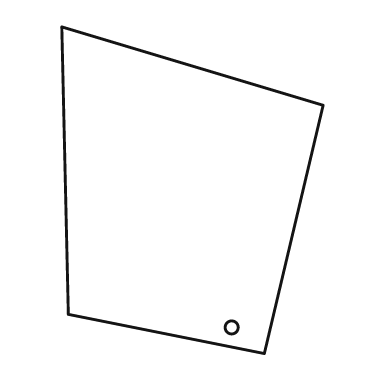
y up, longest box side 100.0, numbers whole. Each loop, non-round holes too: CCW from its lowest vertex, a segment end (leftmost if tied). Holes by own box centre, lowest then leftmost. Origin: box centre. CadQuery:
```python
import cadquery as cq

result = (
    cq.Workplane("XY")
    .moveTo(22.0, -50.0)
    .lineTo(40.0, 26.0)
    .lineTo(-40.0, 50.0)
    .lineTo(-38.0, -38.0)
    .close()
    .moveTo(12.0, -42.0)
    .circle(2.0)
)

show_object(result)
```